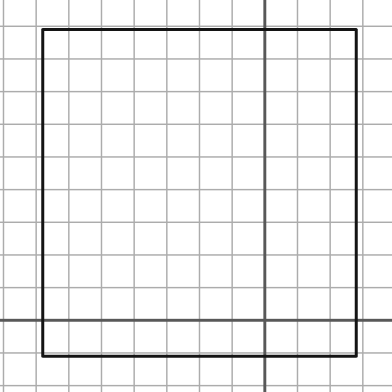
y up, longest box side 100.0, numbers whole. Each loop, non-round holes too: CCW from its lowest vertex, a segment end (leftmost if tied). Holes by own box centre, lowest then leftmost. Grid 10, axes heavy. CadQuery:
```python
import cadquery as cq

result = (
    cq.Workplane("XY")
    .moveTo(-68.0, -11.0)
    .lineTo(28.0, -11.0)
    .lineTo(28.0, 89.0)
    .lineTo(-68.0, 89.0)
    .close()
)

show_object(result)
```